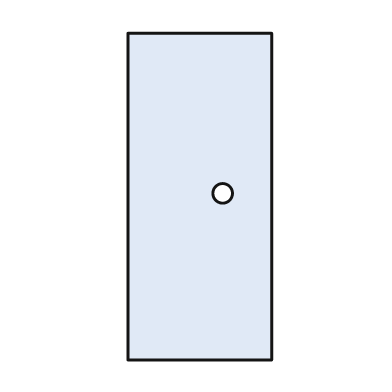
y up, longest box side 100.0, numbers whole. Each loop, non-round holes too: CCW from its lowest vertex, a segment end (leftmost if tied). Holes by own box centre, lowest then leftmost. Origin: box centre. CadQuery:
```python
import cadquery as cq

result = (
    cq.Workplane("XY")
    .moveTo(-22.0, -50.0)
    .lineTo(22.0, -50.0)
    .lineTo(22.0, 50.0)
    .lineTo(-22.0, 50.0)
    .close()
    .moveTo(7.0, 1.0)
    .circle(3.0)
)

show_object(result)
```